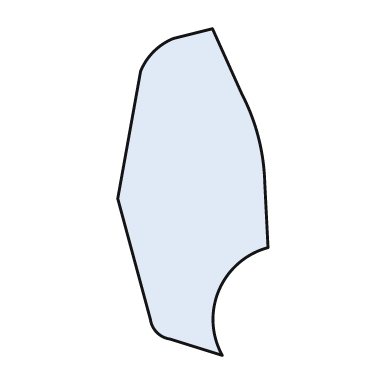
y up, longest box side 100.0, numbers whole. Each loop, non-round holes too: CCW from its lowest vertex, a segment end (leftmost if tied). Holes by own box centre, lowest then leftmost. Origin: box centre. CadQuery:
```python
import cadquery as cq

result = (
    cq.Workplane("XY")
    .moveTo(9.0, -50.0)
    .threePointArc((8.0, -30.0), (23.0, -17.0))
    .lineTo(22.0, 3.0)
    .threePointArc((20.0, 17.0), (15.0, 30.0))
    .lineTo(6.0, 50.0)
    .lineTo(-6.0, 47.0)
    .threePointArc((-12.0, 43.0), (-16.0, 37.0))
    .lineTo(-23.0, -2.0)
    .lineTo(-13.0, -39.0)
    .threePointArc((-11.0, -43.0), (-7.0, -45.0))
    .close()
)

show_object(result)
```